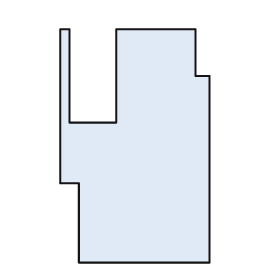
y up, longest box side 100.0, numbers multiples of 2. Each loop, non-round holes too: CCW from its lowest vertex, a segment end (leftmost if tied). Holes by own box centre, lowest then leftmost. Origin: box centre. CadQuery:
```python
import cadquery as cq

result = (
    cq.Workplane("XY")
    .moveTo(-24.0, -50.0)
    .lineTo(32.0, -50.0)
    .lineTo(32.0, 30.0)
    .lineTo(26.0, 30.0)
    .lineTo(26.0, 50.0)
    .lineTo(-8.0, 50.0)
    .lineTo(-8.0, 10.0)
    .lineTo(-28.0, 10.0)
    .lineTo(-28.0, 50.0)
    .lineTo(-32.0, 50.0)
    .lineTo(-32.0, -16.0)
    .lineTo(-24.0, -16.0)
    .close()
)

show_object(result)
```